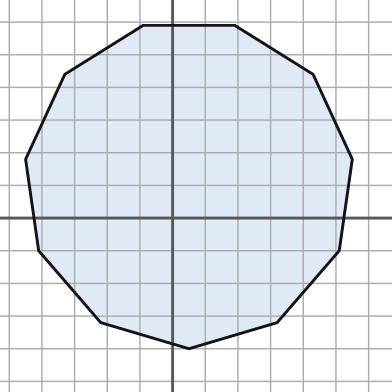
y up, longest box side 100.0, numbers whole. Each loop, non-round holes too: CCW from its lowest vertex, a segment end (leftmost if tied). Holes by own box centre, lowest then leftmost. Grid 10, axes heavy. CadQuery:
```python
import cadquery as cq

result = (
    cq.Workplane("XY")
    .moveTo(5.0, -40.0)
    .lineTo(32.0, -32.0)
    .lineTo(51.0, -10.0)
    .lineTo(55.0, 18.0)
    .lineTo(43.0, 44.0)
    .lineTo(19.0, 59.0)
    .lineTo(-9.0, 59.0)
    .lineTo(-33.0, 44.0)
    .lineTo(-45.0, 18.0)
    .lineTo(-41.0, -10.0)
    .lineTo(-22.0, -32.0)
    .close()
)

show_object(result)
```